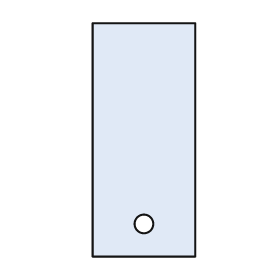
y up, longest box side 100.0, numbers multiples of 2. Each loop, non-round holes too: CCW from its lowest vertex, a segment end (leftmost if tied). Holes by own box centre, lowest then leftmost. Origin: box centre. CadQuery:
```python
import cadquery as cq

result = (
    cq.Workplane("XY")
    .moveTo(-22.0, -50.0)
    .lineTo(22.0, -50.0)
    .lineTo(22.0, 50.0)
    .lineTo(-22.0, 50.0)
    .close()
    .moveTo(0.0, -36.0)
    .circle(4.0)
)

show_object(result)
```